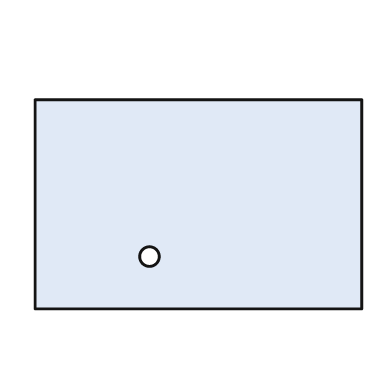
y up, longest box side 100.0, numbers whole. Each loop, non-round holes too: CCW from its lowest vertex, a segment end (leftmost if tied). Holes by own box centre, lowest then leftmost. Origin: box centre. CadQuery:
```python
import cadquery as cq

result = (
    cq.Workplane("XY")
    .moveTo(-50.0, -32.0)
    .lineTo(50.0, -32.0)
    .lineTo(50.0, 32.0)
    .lineTo(-50.0, 32.0)
    .close()
    .moveTo(-15.0, -16.0)
    .circle(3.0)
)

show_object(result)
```